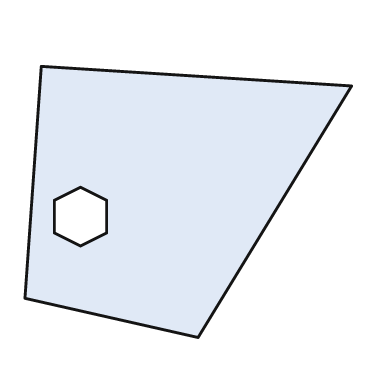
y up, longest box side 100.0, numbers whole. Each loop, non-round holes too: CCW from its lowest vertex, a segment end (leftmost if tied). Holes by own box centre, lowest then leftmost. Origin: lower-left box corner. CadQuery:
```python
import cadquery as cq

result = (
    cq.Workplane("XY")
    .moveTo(53.0, 0.0)
    .lineTo(100.0, 77.0)
    .lineTo(5.0, 83.0)
    .lineTo(0.0, 12.0)
    .close()
    .moveTo(17.0, 28.0)
    .lineTo(25.0, 32.0)
    .lineTo(25.0, 42.0)
    .lineTo(17.0, 46.0)
    .lineTo(9.0, 42.0)
    .lineTo(9.0, 32.0)
    .close()
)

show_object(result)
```